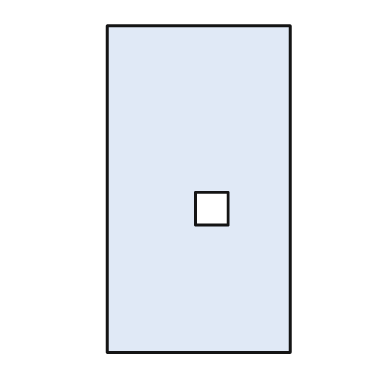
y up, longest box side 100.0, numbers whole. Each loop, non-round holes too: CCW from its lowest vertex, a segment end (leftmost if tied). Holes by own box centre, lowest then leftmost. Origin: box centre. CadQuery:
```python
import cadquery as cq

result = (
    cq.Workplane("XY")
    .moveTo(-28.0, -50.0)
    .lineTo(28.0, -50.0)
    .lineTo(28.0, 50.0)
    .lineTo(-28.0, 50.0)
    .close()
    .moveTo(-1.0, -11.0)
    .lineTo(9.0, -11.0)
    .lineTo(9.0, -1.0)
    .lineTo(-1.0, -1.0)
    .close()
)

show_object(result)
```